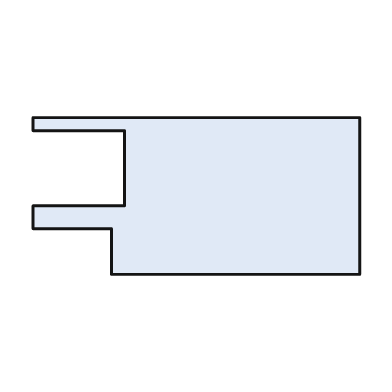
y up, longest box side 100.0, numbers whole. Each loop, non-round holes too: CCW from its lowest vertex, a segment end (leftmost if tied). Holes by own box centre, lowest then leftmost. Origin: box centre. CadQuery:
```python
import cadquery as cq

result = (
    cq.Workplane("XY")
    .moveTo(-26.0, -24.0)
    .lineTo(50.0, -24.0)
    .lineTo(50.0, 24.0)
    .lineTo(-50.0, 24.0)
    .lineTo(-50.0, 20.0)
    .lineTo(-22.0, 20.0)
    .lineTo(-22.0, -3.0)
    .lineTo(-50.0, -3.0)
    .lineTo(-50.0, -10.0)
    .lineTo(-26.0, -10.0)
    .close()
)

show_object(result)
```